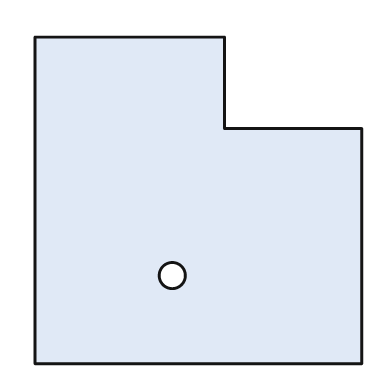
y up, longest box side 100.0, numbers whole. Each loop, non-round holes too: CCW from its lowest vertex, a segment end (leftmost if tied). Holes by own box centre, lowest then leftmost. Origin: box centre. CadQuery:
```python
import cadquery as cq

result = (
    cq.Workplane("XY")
    .moveTo(-50.0, -50.0)
    .lineTo(50.0, -50.0)
    .lineTo(50.0, 22.0)
    .lineTo(8.0, 22.0)
    .lineTo(8.0, 50.0)
    .lineTo(-50.0, 50.0)
    .close()
    .moveTo(-8.0, -23.0)
    .circle(4.0)
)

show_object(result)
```